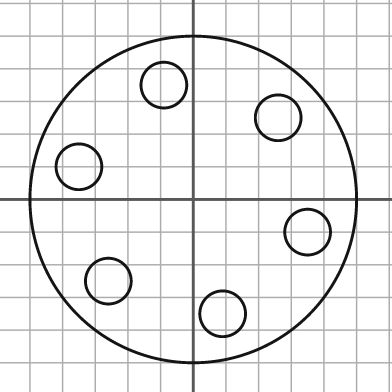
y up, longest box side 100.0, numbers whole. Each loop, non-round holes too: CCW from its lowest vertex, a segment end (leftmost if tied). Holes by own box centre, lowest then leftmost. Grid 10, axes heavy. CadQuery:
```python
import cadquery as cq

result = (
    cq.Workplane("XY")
    .moveTo(0.0, 0.0)
    .circle(50.0)
    .moveTo(9.0, -35.0)
    .circle(7.0)
    .moveTo(-26.0, -25.0)
    .circle(7.0)
    .moveTo(35.0, -10.0)
    .circle(7.0)
    .moveTo(-35.0, 10.0)
    .circle(7.0)
    .moveTo(26.0, 25.0)
    .circle(7.0)
    .moveTo(-9.0, 35.0)
    .circle(7.0)
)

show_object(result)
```